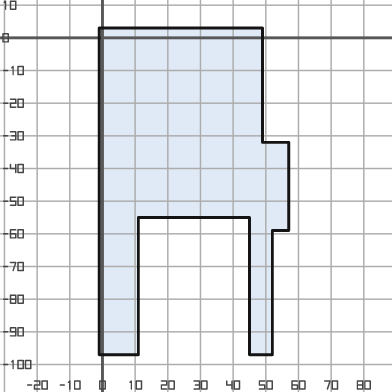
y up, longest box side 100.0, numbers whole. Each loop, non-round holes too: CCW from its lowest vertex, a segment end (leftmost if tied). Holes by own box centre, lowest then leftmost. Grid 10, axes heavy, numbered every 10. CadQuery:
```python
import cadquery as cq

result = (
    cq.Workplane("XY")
    .moveTo(-1.0, -97.0)
    .lineTo(11.0, -97.0)
    .lineTo(11.0, -55.0)
    .lineTo(45.0, -55.0)
    .lineTo(45.0, -97.0)
    .lineTo(52.0, -97.0)
    .lineTo(52.0, -59.0)
    .lineTo(57.0, -59.0)
    .lineTo(57.0, -32.0)
    .lineTo(49.0, -32.0)
    .lineTo(49.0, 3.0)
    .lineTo(-1.0, 3.0)
    .close()
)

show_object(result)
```